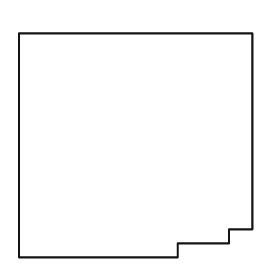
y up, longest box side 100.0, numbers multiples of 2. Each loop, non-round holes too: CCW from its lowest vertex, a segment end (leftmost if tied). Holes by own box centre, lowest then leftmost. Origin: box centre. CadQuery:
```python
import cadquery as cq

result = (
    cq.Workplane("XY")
    .moveTo(-50.0, -48.0)
    .lineTo(18.0, -48.0)
    .lineTo(18.0, -42.0)
    .lineTo(40.0, -42.0)
    .lineTo(40.0, -36.0)
    .lineTo(50.0, -36.0)
    .lineTo(50.0, 48.0)
    .lineTo(-50.0, 48.0)
    .close()
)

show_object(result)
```